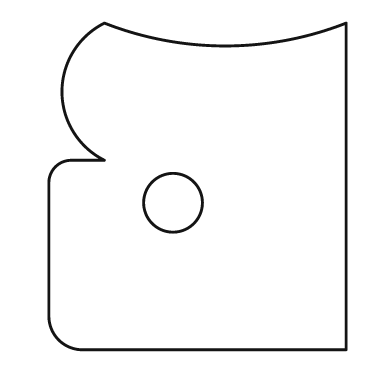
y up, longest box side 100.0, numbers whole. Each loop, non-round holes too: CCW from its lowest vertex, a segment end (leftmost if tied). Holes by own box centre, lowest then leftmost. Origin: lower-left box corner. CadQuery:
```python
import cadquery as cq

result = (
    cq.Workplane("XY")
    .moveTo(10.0, 0.0)
    .lineTo(91.0, 0.0)
    .lineTo(91.0, 100.0)
    .threePointArc((54.0, 93.0), (17.0, 100.0))
    .threePointArc((4.0, 79.0), (17.0, 58.0))
    .lineTo(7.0, 58.0)
    .threePointArc((2.0, 56.0), (0.0, 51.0))
    .lineTo(0.0, 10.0)
    .threePointArc((3.0, 3.0), (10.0, 0.0))
    .close()
    .moveTo(38.0, 45.0)
    .circle(9.0)
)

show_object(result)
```